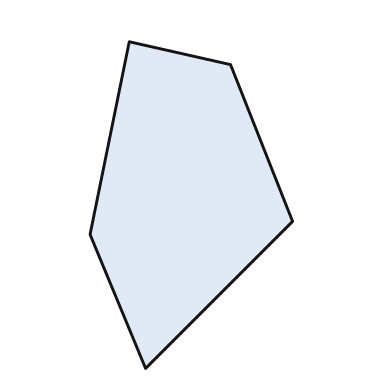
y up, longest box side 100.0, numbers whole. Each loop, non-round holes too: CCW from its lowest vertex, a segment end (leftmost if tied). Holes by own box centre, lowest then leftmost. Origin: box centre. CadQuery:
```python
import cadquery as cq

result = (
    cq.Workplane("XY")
    .moveTo(-14.0, -50.0)
    .lineTo(31.0, -5.0)
    .lineTo(12.0, 43.0)
    .lineTo(-19.0, 50.0)
    .lineTo(-31.0, -9.0)
    .close()
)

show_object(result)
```